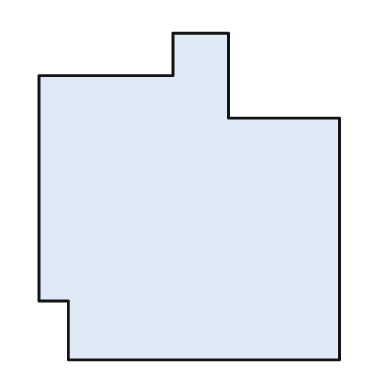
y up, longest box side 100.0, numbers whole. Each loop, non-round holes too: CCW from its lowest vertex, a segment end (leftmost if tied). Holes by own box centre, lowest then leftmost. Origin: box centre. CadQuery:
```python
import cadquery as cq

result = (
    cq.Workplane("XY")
    .moveTo(-37.0, -50.0)
    .lineTo(46.0, -50.0)
    .lineTo(46.0, 24.0)
    .lineTo(12.0, 24.0)
    .lineTo(12.0, 50.0)
    .lineTo(-5.0, 50.0)
    .lineTo(-5.0, 37.0)
    .lineTo(-46.0, 37.0)
    .lineTo(-46.0, -32.0)
    .lineTo(-37.0, -32.0)
    .close()
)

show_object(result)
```